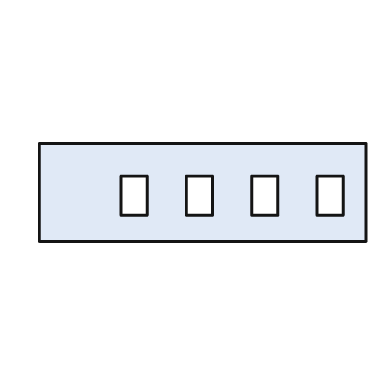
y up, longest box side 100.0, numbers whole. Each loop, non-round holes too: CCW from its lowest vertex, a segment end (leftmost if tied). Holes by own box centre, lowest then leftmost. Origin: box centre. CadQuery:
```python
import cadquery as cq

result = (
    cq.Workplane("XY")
    .moveTo(-50.0, -15.0)
    .lineTo(50.0, -15.0)
    .lineTo(50.0, 15.0)
    .lineTo(-50.0, 15.0)
    .close()
    .moveTo(-25.0, -7.0)
    .lineTo(-17.0, -7.0)
    .lineTo(-17.0, 5.0)
    .lineTo(-25.0, 5.0)
    .close()
    .moveTo(-5.0, -7.0)
    .lineTo(3.0, -7.0)
    .lineTo(3.0, 5.0)
    .lineTo(-5.0, 5.0)
    .close()
    .moveTo(15.0, -7.0)
    .lineTo(23.0, -7.0)
    .lineTo(23.0, 5.0)
    .lineTo(15.0, 5.0)
    .close()
    .moveTo(35.0, -7.0)
    .lineTo(43.0, -7.0)
    .lineTo(43.0, 5.0)
    .lineTo(35.0, 5.0)
    .close()
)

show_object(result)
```